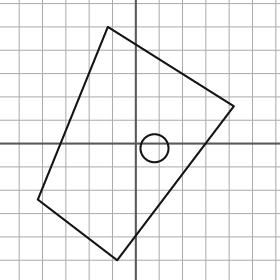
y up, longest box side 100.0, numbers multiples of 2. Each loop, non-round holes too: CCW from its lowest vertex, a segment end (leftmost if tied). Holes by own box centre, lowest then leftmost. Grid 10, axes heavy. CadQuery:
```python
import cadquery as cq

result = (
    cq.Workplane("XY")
    .moveTo(-8.0, -50.0)
    .lineTo(42.0, 16.0)
    .lineTo(-12.0, 50.0)
    .lineTo(-42.0, -24.0)
    .close()
    .moveTo(8.0, -2.0)
    .circle(6.0)
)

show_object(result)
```